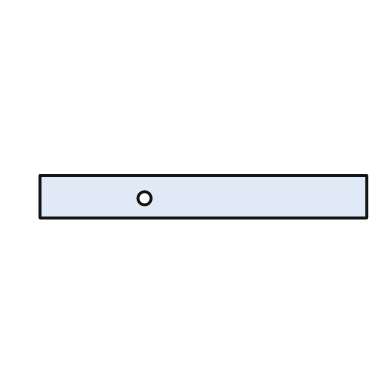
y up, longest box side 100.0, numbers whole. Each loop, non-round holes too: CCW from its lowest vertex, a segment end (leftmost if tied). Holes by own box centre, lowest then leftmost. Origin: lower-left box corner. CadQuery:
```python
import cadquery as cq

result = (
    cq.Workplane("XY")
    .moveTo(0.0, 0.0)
    .lineTo(100.0, 0.0)
    .lineTo(100.0, 13.0)
    .lineTo(0.0, 13.0)
    .close()
    .moveTo(32.0, 6.0)
    .circle(2.0)
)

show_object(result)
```